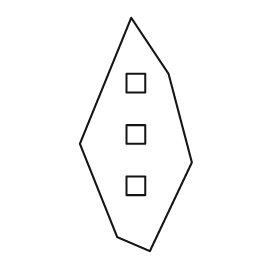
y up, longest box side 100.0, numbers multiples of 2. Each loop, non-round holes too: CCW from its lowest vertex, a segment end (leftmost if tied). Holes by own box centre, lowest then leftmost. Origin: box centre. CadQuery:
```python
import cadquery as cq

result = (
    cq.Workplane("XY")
    .moveTo(6.0, -50.0)
    .lineTo(24.0, -12.0)
    .lineTo(14.0, 26.0)
    .lineTo(-2.0, 50.0)
    .lineTo(-24.0, -4.0)
    .lineTo(-8.0, -44.0)
    .close()
    .moveTo(-4.0, -26.0)
    .lineTo(4.0, -26.0)
    .lineTo(4.0, -18.0)
    .lineTo(-4.0, -18.0)
    .close()
    .moveTo(-4.0, -4.0)
    .lineTo(4.0, -4.0)
    .lineTo(4.0, 4.0)
    .lineTo(-4.0, 4.0)
    .close()
    .moveTo(-4.0, 18.0)
    .lineTo(4.0, 18.0)
    .lineTo(4.0, 26.0)
    .lineTo(-4.0, 26.0)
    .close()
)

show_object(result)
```